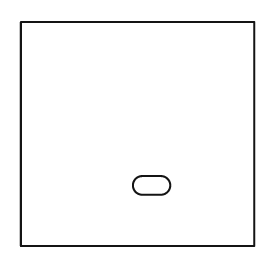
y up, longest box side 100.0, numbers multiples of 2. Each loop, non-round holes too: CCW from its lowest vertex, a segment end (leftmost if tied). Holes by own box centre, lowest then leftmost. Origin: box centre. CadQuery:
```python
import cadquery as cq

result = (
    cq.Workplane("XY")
    .moveTo(-50.0, -48.0)
    .lineTo(50.0, -48.0)
    .lineTo(50.0, 48.0)
    .lineTo(-50.0, 48.0)
    .close()
    .moveTo(2.0, -26.0)
    .lineTo(10.0, -26.0)
    .threePointArc((14.0, -22.0), (10.0, -18.0))
    .lineTo(2.0, -18.0)
    .threePointArc((-2.0, -22.0), (2.0, -26.0))
    .close()
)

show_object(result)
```